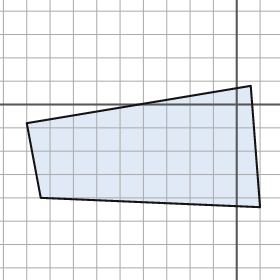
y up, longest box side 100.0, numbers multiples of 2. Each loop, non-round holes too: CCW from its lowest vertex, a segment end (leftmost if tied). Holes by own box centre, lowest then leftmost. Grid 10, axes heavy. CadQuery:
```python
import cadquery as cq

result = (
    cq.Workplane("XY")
    .moveTo(10.0, -44.0)
    .lineTo(6.0, 8.0)
    .lineTo(-90.0, -8.0)
    .lineTo(-84.0, -40.0)
    .close()
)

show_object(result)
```